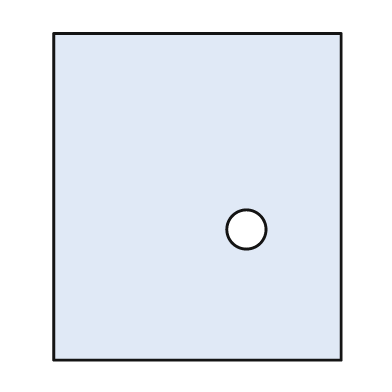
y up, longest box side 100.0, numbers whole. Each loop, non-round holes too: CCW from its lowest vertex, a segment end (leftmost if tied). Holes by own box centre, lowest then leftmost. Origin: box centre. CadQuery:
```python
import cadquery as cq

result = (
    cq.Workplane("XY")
    .moveTo(-44.0, -50.0)
    .lineTo(44.0, -50.0)
    .lineTo(44.0, 50.0)
    .lineTo(-44.0, 50.0)
    .close()
    .moveTo(15.0, -10.0)
    .circle(6.0)
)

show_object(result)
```